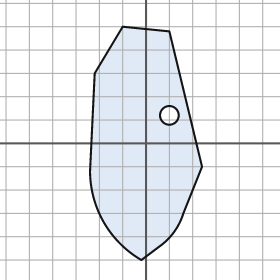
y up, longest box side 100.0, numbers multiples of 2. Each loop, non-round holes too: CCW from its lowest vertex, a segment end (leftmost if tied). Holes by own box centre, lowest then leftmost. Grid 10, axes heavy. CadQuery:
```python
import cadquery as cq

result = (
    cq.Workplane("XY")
    .moveTo(-2.0, -50.0)
    .lineTo(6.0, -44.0)
    .threePointArc((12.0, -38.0), (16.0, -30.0))
    .lineTo(24.0, -10.0)
    .lineTo(10.0, 48.0)
    .lineTo(-10.0, 50.0)
    .lineTo(-22.0, 30.0)
    .lineTo(-24.0, -12.0)
    .threePointArc((-18.0, -34.0), (-2.0, -50.0))
    .close()
    .moveTo(10.0, 12.0)
    .circle(4.0)
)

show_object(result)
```